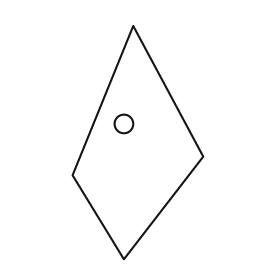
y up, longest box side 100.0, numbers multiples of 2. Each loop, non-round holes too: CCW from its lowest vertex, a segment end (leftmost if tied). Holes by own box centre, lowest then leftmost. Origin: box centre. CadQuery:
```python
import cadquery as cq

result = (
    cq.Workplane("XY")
    .moveTo(-6.0, -50.0)
    .lineTo(28.0, -6.0)
    .lineTo(-2.0, 50.0)
    .lineTo(-28.0, -14.0)
    .close()
    .moveTo(-6.0, 8.0)
    .circle(4.0)
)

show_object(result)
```